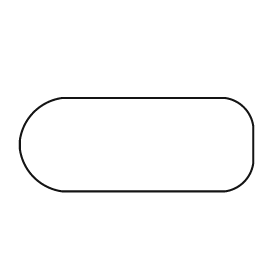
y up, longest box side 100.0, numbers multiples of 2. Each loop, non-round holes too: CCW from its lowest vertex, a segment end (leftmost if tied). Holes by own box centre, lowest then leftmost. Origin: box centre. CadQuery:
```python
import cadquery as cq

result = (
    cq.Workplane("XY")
    .moveTo(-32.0, -20.0)
    .lineTo(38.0, -20.0)
    .threePointArc((46.0, -16.0), (50.0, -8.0))
    .lineTo(50.0, 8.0)
    .threePointArc((46.0, 16.0), (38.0, 20.0))
    .lineTo(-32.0, 20.0)
    .threePointArc((-44.0, 14.0), (-50.0, 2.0))
    .lineTo(-50.0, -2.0)
    .threePointArc((-44.0, -14.0), (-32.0, -20.0))
    .close()
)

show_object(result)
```